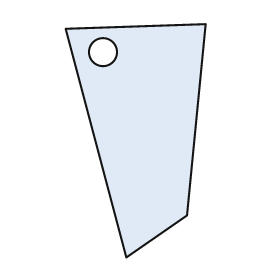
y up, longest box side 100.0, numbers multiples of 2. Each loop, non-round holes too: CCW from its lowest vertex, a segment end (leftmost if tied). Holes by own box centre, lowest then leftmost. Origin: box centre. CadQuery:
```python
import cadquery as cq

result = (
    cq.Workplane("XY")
    .moveTo(-4.0, -50.0)
    .lineTo(22.0, -32.0)
    .lineTo(30.0, 50.0)
    .lineTo(-30.0, 48.0)
    .close()
    .moveTo(-14.0, 38.0)
    .circle(6.0)
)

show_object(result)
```